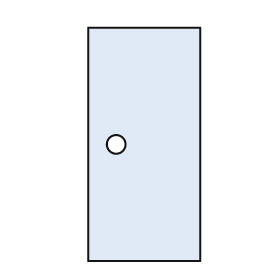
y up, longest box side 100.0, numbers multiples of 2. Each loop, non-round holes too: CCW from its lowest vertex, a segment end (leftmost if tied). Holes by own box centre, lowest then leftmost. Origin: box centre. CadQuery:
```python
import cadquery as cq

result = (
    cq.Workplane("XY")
    .moveTo(-24.0, -50.0)
    .lineTo(24.0, -50.0)
    .lineTo(24.0, 50.0)
    .lineTo(-24.0, 50.0)
    .close()
    .moveTo(-12.0, 0.0)
    .circle(4.0)
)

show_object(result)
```